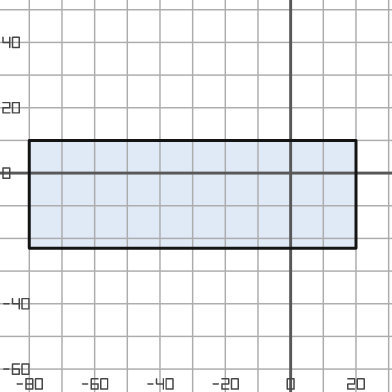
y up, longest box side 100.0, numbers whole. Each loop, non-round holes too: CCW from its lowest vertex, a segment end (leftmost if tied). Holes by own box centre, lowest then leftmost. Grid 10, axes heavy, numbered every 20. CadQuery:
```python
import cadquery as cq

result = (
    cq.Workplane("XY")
    .moveTo(-80.0, -23.0)
    .lineTo(20.0, -23.0)
    .lineTo(20.0, 10.0)
    .lineTo(-80.0, 10.0)
    .close()
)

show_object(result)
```